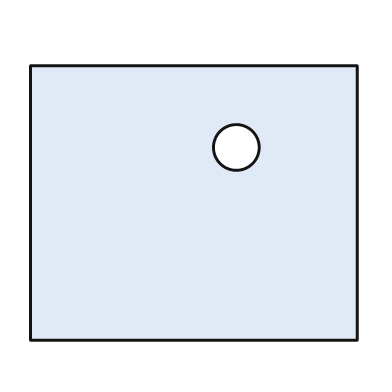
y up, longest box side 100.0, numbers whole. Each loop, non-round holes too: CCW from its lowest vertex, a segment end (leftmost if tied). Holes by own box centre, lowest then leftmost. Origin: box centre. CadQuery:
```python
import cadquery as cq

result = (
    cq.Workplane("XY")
    .moveTo(-50.0, -42.0)
    .lineTo(50.0, -42.0)
    .lineTo(50.0, 42.0)
    .lineTo(-50.0, 42.0)
    .close()
    .moveTo(13.0, 17.0)
    .circle(7.0)
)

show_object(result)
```